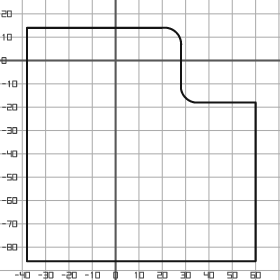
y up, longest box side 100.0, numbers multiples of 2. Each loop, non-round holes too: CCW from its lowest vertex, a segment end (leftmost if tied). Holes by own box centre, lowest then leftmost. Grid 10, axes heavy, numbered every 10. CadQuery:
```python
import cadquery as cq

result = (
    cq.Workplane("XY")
    .moveTo(-38.0, -86.0)
    .lineTo(60.0, -86.0)
    .lineTo(60.0, -18.0)
    .lineTo(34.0, -18.0)
    .threePointArc((30.0, -16.0), (28.0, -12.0))
    .lineTo(28.0, 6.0)
    .threePointArc((26.0, 12.0), (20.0, 14.0))
    .lineTo(-38.0, 14.0)
    .close()
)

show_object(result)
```